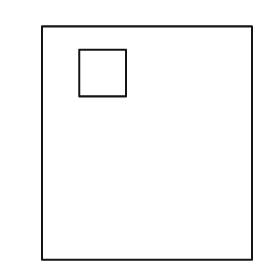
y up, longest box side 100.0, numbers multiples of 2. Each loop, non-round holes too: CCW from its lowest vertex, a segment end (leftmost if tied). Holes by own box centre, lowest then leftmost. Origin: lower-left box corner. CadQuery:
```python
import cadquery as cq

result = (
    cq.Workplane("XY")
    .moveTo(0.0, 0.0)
    .lineTo(90.0, 0.0)
    .lineTo(90.0, 100.0)
    .lineTo(0.0, 100.0)
    .close()
    .moveTo(16.0, 70.0)
    .lineTo(36.0, 70.0)
    .lineTo(36.0, 90.0)
    .lineTo(16.0, 90.0)
    .close()
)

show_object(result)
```